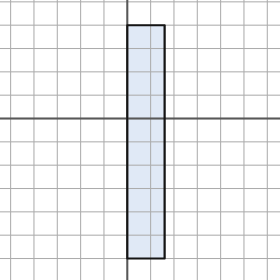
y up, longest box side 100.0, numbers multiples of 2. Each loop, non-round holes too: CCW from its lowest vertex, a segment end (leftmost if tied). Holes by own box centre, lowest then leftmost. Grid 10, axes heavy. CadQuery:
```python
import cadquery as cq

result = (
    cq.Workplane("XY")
    .moveTo(0.0, -60.0)
    .lineTo(16.0, -60.0)
    .lineTo(16.0, 40.0)
    .lineTo(0.0, 40.0)
    .close()
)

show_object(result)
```